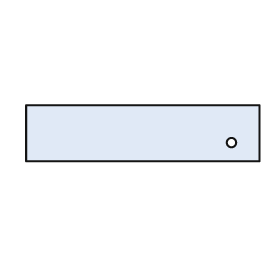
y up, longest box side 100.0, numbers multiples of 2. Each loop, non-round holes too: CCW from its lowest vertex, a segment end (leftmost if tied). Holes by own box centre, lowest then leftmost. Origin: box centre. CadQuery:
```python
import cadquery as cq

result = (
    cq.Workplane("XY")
    .moveTo(-50.0, -12.0)
    .lineTo(50.0, -12.0)
    .lineTo(50.0, 12.0)
    .lineTo(-50.0, 12.0)
    .close()
    .moveTo(38.0, -4.0)
    .circle(2.0)
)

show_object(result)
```